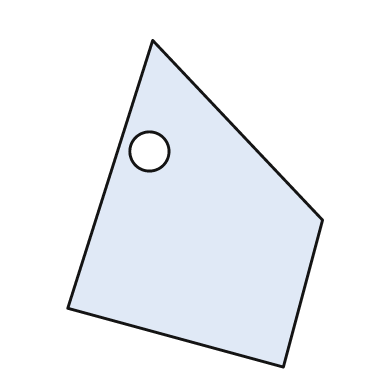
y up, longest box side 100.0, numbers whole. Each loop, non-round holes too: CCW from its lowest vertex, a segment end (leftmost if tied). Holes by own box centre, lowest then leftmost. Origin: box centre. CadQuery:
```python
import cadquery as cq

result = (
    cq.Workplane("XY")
    .moveTo(27.0, -50.0)
    .lineTo(39.0, -5.0)
    .lineTo(-13.0, 50.0)
    .lineTo(-39.0, -32.0)
    .close()
    .moveTo(-14.0, 16.0)
    .circle(6.0)
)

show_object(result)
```